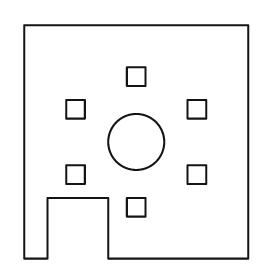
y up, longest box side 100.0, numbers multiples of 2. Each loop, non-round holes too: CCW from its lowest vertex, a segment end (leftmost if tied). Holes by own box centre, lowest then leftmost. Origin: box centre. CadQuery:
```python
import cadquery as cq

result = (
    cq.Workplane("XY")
    .moveTo(-48.0, -50.0)
    .lineTo(-38.0, -50.0)
    .lineTo(-38.0, -24.0)
    .lineTo(-12.0, -24.0)
    .lineTo(-12.0, -50.0)
    .lineTo(48.0, -50.0)
    .lineTo(48.0, 50.0)
    .lineTo(-48.0, 50.0)
    .close()
    .moveTo(-4.0, -32.0)
    .lineTo(4.0, -32.0)
    .lineTo(4.0, -24.0)
    .lineTo(-4.0, -24.0)
    .close()
    .moveTo(-30.0, -18.0)
    .lineTo(-22.0, -18.0)
    .lineTo(-22.0, -10.0)
    .lineTo(-30.0, -10.0)
    .close()
    .moveTo(22.0, -18.0)
    .lineTo(30.0, -18.0)
    .lineTo(30.0, -10.0)
    .lineTo(22.0, -10.0)
    .close()
    .moveTo(0.0, 0.0)
    .circle(12.0)
    .moveTo(-30.0, 10.0)
    .lineTo(-22.0, 10.0)
    .lineTo(-22.0, 18.0)
    .lineTo(-30.0, 18.0)
    .close()
    .moveTo(22.0, 10.0)
    .lineTo(30.0, 10.0)
    .lineTo(30.0, 18.0)
    .lineTo(22.0, 18.0)
    .close()
    .moveTo(-4.0, 24.0)
    .lineTo(4.0, 24.0)
    .lineTo(4.0, 32.0)
    .lineTo(-4.0, 32.0)
    .close()
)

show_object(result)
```